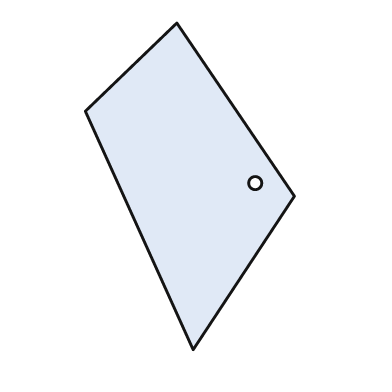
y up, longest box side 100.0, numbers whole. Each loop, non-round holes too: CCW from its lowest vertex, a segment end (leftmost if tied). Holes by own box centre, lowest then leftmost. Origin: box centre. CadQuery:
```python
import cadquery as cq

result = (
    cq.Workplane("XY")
    .moveTo(1.0, -50.0)
    .lineTo(32.0, -3.0)
    .lineTo(-4.0, 50.0)
    .lineTo(-32.0, 23.0)
    .close()
    .moveTo(20.0, 1.0)
    .circle(2.0)
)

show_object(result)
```